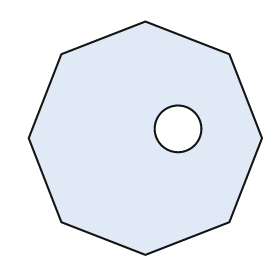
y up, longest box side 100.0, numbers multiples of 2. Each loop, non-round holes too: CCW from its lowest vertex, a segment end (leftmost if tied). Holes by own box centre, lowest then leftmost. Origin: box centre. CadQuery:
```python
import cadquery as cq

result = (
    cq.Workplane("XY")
    .moveTo(0.0, -50.0)
    .lineTo(36.0, -36.0)
    .lineTo(50.0, 0.0)
    .lineTo(36.0, 36.0)
    .lineTo(0.0, 50.0)
    .lineTo(-36.0, 36.0)
    .lineTo(-50.0, 0.0)
    .lineTo(-36.0, -36.0)
    .close()
    .moveTo(14.0, 4.0)
    .circle(10.0)
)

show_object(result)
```